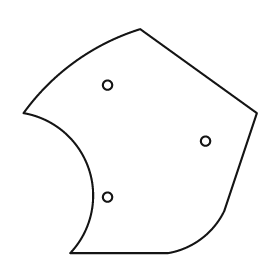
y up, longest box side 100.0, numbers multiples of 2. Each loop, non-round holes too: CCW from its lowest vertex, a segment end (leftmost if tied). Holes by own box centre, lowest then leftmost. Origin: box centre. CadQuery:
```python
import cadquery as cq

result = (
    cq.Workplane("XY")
    .moveTo(-30.0, -48.0)
    .lineTo(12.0, -48.0)
    .threePointArc((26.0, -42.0), (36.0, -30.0))
    .lineTo(50.0, 12.0)
    .lineTo(0.0, 48.0)
    .threePointArc((-28.0, 34.0), (-50.0, 12.0))
    .threePointArc((-22.0, -12.0), (-30.0, -48.0))
    .close()
    .moveTo(-14.0, -24.0)
    .circle(2.0)
    .moveTo(28.0, 0.0)
    .circle(2.0)
    .moveTo(-14.0, 24.0)
    .circle(2.0)
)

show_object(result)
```